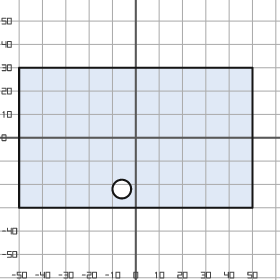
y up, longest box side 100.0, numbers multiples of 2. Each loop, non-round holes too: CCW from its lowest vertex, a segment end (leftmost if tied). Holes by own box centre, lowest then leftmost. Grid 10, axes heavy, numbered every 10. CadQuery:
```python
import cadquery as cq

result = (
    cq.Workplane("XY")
    .moveTo(-50.0, -30.0)
    .lineTo(50.0, -30.0)
    .lineTo(50.0, 30.0)
    .lineTo(-50.0, 30.0)
    .close()
    .moveTo(-6.0, -22.0)
    .circle(4.0)
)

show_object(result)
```